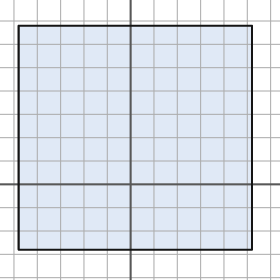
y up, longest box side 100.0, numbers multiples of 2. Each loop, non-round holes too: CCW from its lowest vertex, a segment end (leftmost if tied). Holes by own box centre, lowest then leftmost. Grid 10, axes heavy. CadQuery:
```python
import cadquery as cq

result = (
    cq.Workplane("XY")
    .moveTo(-48.0, -28.0)
    .lineTo(52.0, -28.0)
    .lineTo(52.0, 68.0)
    .lineTo(-48.0, 68.0)
    .close()
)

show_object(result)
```